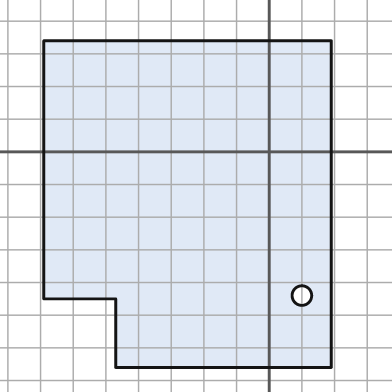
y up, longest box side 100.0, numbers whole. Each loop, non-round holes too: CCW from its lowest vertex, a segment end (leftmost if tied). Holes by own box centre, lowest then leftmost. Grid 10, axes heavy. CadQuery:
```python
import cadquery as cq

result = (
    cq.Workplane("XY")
    .moveTo(-47.0, -66.0)
    .lineTo(19.0, -66.0)
    .lineTo(19.0, 34.0)
    .lineTo(-69.0, 34.0)
    .lineTo(-69.0, -45.0)
    .lineTo(-47.0, -45.0)
    .close()
    .moveTo(10.0, -44.0)
    .circle(3.0)
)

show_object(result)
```